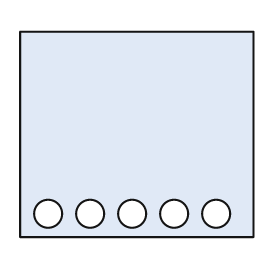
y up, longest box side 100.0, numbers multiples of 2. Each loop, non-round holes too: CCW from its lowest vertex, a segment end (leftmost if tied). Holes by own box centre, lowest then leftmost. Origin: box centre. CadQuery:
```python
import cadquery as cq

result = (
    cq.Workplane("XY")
    .moveTo(-50.0, -44.0)
    .lineTo(50.0, -44.0)
    .lineTo(50.0, 44.0)
    .lineTo(-50.0, 44.0)
    .close()
    .moveTo(-38.0, -34.0)
    .circle(6.0)
    .moveTo(-20.0, -34.0)
    .circle(6.0)
    .moveTo(-2.0, -34.0)
    .circle(6.0)
    .moveTo(16.0, -34.0)
    .circle(6.0)
    .moveTo(34.0, -34.0)
    .circle(6.0)
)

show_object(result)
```